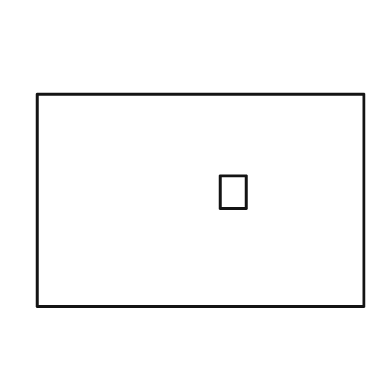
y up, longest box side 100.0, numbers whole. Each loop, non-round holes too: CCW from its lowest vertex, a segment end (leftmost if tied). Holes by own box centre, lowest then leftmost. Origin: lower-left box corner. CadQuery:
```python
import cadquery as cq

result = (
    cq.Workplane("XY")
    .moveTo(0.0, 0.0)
    .lineTo(100.0, 0.0)
    .lineTo(100.0, 65.0)
    .lineTo(0.0, 65.0)
    .close()
    .moveTo(56.0, 30.0)
    .lineTo(64.0, 30.0)
    .lineTo(64.0, 40.0)
    .lineTo(56.0, 40.0)
    .close()
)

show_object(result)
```